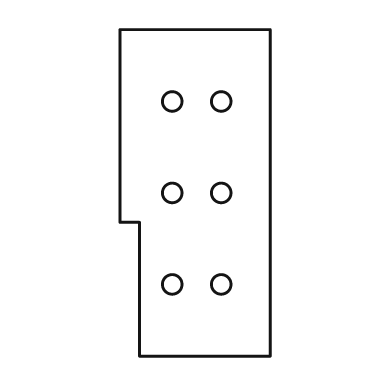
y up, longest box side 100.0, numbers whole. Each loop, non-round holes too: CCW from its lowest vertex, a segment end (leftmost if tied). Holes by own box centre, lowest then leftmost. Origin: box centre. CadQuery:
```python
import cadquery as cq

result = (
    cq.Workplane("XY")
    .moveTo(-17.0, -50.0)
    .lineTo(23.0, -50.0)
    .lineTo(23.0, 50.0)
    .lineTo(-23.0, 50.0)
    .lineTo(-23.0, -9.0)
    .lineTo(-17.0, -9.0)
    .close()
    .moveTo(-7.0, -28.0)
    .circle(3.0)
    .moveTo(8.0, -28.0)
    .circle(3.0)
    .moveTo(-7.0, 0.0)
    .circle(3.0)
    .moveTo(8.0, 0.0)
    .circle(3.0)
    .moveTo(-7.0, 28.0)
    .circle(3.0)
    .moveTo(8.0, 28.0)
    .circle(3.0)
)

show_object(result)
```